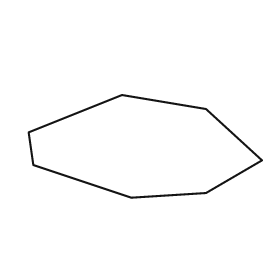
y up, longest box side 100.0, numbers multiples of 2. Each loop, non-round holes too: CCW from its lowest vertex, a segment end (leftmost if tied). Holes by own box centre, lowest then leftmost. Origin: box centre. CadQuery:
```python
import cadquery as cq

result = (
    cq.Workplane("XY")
    .moveTo(-6.0, -22.0)
    .lineTo(26.0, -20.0)
    .lineTo(50.0, -6.0)
    .lineTo(26.0, 16.0)
    .lineTo(-10.0, 22.0)
    .lineTo(-50.0, 6.0)
    .lineTo(-48.0, -8.0)
    .close()
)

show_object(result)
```